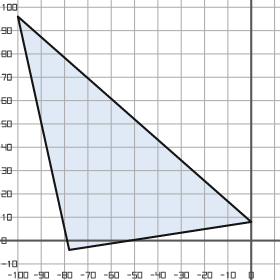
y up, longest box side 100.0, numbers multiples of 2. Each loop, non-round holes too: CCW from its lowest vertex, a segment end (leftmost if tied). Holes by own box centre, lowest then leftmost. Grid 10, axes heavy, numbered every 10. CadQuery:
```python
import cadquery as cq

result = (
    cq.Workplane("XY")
    .moveTo(-78.0, -4.0)
    .lineTo(0.0, 8.0)
    .lineTo(-100.0, 96.0)
    .close()
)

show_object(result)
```